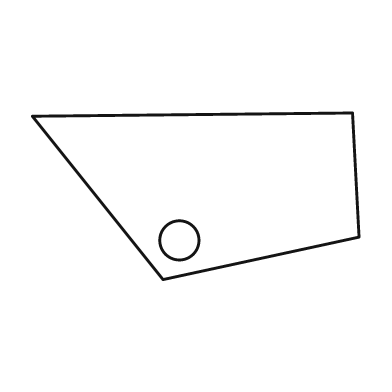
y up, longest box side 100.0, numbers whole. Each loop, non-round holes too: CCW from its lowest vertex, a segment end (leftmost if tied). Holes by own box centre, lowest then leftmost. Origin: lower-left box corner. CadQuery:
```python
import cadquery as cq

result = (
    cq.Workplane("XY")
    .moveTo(40.0, 0.0)
    .lineTo(100.0, 13.0)
    .lineTo(98.0, 51.0)
    .lineTo(0.0, 50.0)
    .close()
    .moveTo(45.0, 12.0)
    .circle(6.0)
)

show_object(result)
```